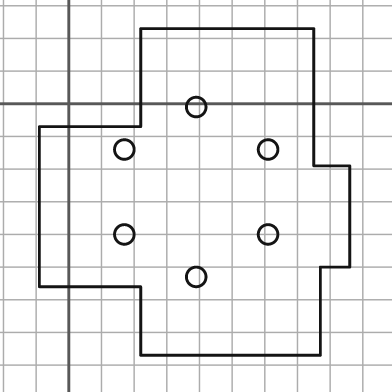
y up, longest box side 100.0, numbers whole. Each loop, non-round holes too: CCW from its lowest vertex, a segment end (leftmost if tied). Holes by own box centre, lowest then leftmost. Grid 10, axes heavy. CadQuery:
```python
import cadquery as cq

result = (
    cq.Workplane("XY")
    .moveTo(22.0, -77.0)
    .lineTo(77.0, -77.0)
    .lineTo(77.0, -50.0)
    .lineTo(86.0, -50.0)
    .lineTo(86.0, -19.0)
    .lineTo(75.0, -19.0)
    .lineTo(75.0, 23.0)
    .lineTo(22.0, 23.0)
    .lineTo(22.0, -7.0)
    .lineTo(-9.0, -7.0)
    .lineTo(-9.0, -56.0)
    .lineTo(22.0, -56.0)
    .close()
    .moveTo(39.0, -53.0)
    .circle(3.0)
    .moveTo(17.0, -40.0)
    .circle(3.0)
    .moveTo(61.0, -40.0)
    .circle(3.0)
    .moveTo(17.0, -14.0)
    .circle(3.0)
    .moveTo(61.0, -14.0)
    .circle(3.0)
    .moveTo(39.0, -1.0)
    .circle(3.0)
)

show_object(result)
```